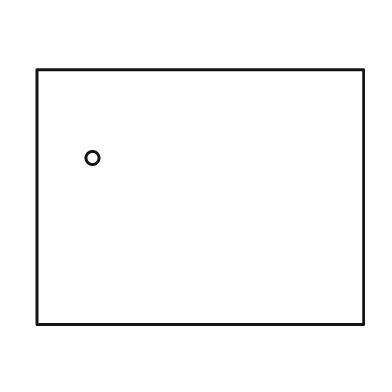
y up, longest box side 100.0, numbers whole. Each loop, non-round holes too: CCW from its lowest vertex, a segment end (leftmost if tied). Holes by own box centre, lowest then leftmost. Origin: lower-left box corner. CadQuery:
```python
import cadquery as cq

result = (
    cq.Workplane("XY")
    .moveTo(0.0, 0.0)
    .lineTo(100.0, 0.0)
    .lineTo(100.0, 78.0)
    .lineTo(0.0, 78.0)
    .close()
    .moveTo(17.0, 51.0)
    .circle(2.0)
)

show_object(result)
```